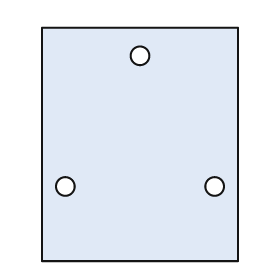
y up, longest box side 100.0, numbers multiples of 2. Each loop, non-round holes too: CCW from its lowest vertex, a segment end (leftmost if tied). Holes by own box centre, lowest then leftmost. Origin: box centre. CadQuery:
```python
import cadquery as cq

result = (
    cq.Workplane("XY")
    .moveTo(-42.0, -50.0)
    .lineTo(42.0, -50.0)
    .lineTo(42.0, 50.0)
    .lineTo(-42.0, 50.0)
    .close()
    .moveTo(-32.0, -18.0)
    .circle(4.0)
    .moveTo(32.0, -18.0)
    .circle(4.0)
    .moveTo(0.0, 38.0)
    .circle(4.0)
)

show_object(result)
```